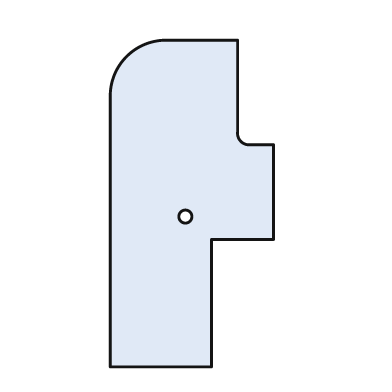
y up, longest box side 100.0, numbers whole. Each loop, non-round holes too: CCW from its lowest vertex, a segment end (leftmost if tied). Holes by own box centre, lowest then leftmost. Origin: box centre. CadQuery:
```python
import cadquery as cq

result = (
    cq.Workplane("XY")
    .moveTo(-25.0, -50.0)
    .lineTo(6.0, -50.0)
    .lineTo(6.0, -11.0)
    .lineTo(25.0, -11.0)
    .lineTo(25.0, 18.0)
    .lineTo(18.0, 18.0)
    .threePointArc((15.0, 19.0), (14.0, 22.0))
    .lineTo(14.0, 50.0)
    .lineTo(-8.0, 50.0)
    .threePointArc((-20.0, 45.0), (-25.0, 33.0))
    .close()
    .moveTo(-2.0, -4.0)
    .circle(2.0)
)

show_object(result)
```